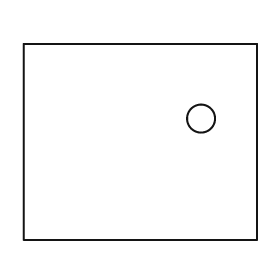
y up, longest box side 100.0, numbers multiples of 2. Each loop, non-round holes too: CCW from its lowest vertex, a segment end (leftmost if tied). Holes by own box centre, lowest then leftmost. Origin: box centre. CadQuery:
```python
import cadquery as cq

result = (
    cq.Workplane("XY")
    .moveTo(-50.0, -42.0)
    .lineTo(50.0, -42.0)
    .lineTo(50.0, 42.0)
    .lineTo(-50.0, 42.0)
    .close()
    .moveTo(26.0, 10.0)
    .circle(6.0)
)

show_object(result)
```